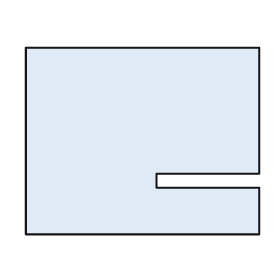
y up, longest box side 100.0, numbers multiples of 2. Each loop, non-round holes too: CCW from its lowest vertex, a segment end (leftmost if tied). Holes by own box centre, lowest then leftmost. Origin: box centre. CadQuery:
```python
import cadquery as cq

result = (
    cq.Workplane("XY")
    .moveTo(-50.0, -40.0)
    .lineTo(50.0, -40.0)
    .lineTo(50.0, -20.0)
    .lineTo(6.0, -20.0)
    .lineTo(6.0, -14.0)
    .lineTo(50.0, -14.0)
    .lineTo(50.0, 40.0)
    .lineTo(-50.0, 40.0)
    .close()
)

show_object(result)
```